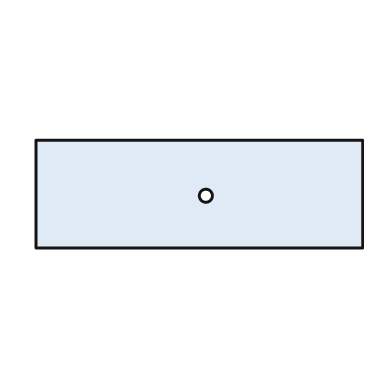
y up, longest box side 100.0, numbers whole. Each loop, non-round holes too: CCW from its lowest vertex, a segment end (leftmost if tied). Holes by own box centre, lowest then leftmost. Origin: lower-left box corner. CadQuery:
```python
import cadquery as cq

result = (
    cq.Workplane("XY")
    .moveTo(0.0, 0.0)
    .lineTo(100.0, 0.0)
    .lineTo(100.0, 33.0)
    .lineTo(0.0, 33.0)
    .close()
    .moveTo(52.0, 16.0)
    .circle(2.0)
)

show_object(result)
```